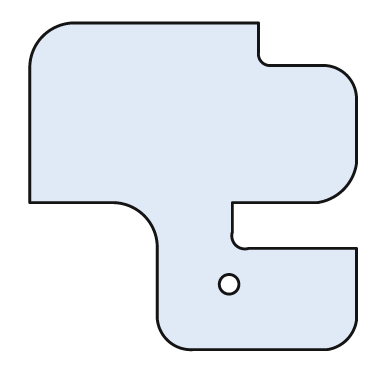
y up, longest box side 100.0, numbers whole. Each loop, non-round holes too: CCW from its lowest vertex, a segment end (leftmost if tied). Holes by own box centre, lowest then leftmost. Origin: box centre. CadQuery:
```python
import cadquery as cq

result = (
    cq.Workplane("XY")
    .moveTo(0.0, -50.0)
    .lineTo(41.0, -50.0)
    .threePointArc((47.0, -47.0), (50.0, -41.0))
    .lineTo(50.0, -19.0)
    .lineTo(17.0, -19.0)
    .threePointArc((13.0, -18.0), (12.0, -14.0))
    .lineTo(12.0, -5.0)
    .lineTo(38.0, -5.0)
    .threePointArc((46.0, -1.0), (50.0, 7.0))
    .lineTo(50.0, 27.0)
    .threePointArc((47.0, 34.0), (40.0, 37.0))
    .lineTo(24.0, 37.0)
    .threePointArc((21.0, 38.0), (20.0, 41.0))
    .lineTo(20.0, 50.0)
    .lineTo(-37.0, 50.0)
    .threePointArc((-46.0, 46.0), (-50.0, 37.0))
    .lineTo(-50.0, -5.0)
    .lineTo(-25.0, -5.0)
    .threePointArc((-15.0, -9.0), (-11.0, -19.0))
    .lineTo(-11.0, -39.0)
    .threePointArc((-8.0, -47.0), (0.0, -50.0))
    .close()
    .moveTo(11.0, -30.0)
    .circle(3.0)
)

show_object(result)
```